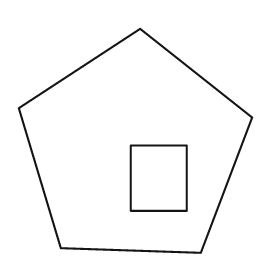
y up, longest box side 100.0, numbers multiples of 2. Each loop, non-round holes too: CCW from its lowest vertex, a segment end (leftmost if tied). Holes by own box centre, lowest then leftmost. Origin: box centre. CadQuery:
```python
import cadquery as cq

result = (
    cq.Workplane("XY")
    .moveTo(28.0, -48.0)
    .lineTo(50.0, 10.0)
    .lineTo(2.0, 48.0)
    .lineTo(-50.0, 14.0)
    .lineTo(-32.0, -46.0)
    .close()
    .moveTo(-2.0, -30.0)
    .lineTo(22.0, -30.0)
    .lineTo(22.0, -2.0)
    .lineTo(-2.0, -2.0)
    .close()
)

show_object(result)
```